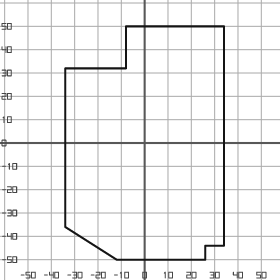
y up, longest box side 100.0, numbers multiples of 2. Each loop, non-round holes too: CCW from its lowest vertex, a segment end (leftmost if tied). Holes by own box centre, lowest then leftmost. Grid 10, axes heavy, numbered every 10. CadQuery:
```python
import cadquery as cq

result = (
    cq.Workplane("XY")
    .moveTo(-12.0, -50.0)
    .lineTo(26.0, -50.0)
    .lineTo(26.0, -44.0)
    .lineTo(34.0, -44.0)
    .lineTo(34.0, 50.0)
    .lineTo(-8.0, 50.0)
    .lineTo(-8.0, 32.0)
    .lineTo(-34.0, 32.0)
    .lineTo(-34.0, -36.0)
    .close()
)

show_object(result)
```